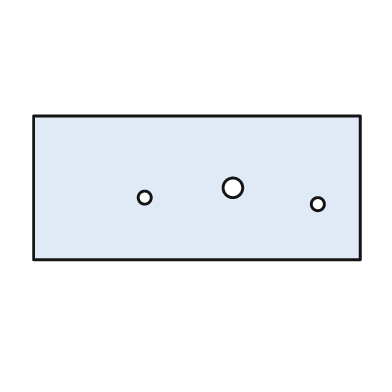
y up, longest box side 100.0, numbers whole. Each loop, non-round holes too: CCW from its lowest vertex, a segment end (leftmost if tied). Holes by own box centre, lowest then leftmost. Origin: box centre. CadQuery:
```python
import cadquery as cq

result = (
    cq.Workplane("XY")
    .moveTo(-50.0, -22.0)
    .lineTo(50.0, -22.0)
    .lineTo(50.0, 22.0)
    .lineTo(-50.0, 22.0)
    .close()
    .moveTo(37.0, -5.0)
    .circle(2.0)
    .moveTo(-16.0, -3.0)
    .circle(2.0)
    .moveTo(11.0, 0.0)
    .circle(3.0)
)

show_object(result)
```